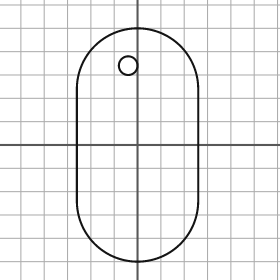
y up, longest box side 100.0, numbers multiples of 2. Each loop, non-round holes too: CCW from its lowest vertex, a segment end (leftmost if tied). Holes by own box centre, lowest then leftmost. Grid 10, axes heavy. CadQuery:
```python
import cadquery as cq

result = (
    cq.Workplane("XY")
    .moveTo(-26.0, -24.0)
    .threePointArc((0.0, -50.0), (26.0, -24.0))
    .lineTo(26.0, 24.0)
    .threePointArc((0.0, 50.0), (-26.0, 24.0))
    .close()
    .moveTo(-4.0, 34.0)
    .circle(4.0)
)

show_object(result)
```